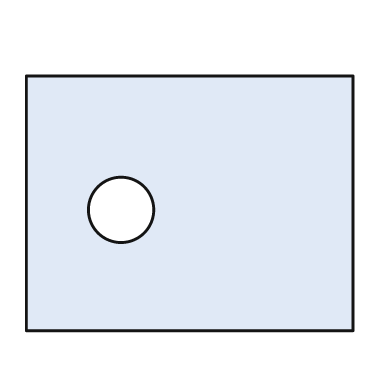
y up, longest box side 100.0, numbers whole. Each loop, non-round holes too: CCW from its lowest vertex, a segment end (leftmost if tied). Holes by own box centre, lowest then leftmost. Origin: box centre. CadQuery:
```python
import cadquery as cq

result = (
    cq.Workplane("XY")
    .moveTo(-50.0, -39.0)
    .lineTo(50.0, -39.0)
    .lineTo(50.0, 39.0)
    .lineTo(-50.0, 39.0)
    .close()
    .moveTo(-21.0, -2.0)
    .circle(10.0)
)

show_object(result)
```